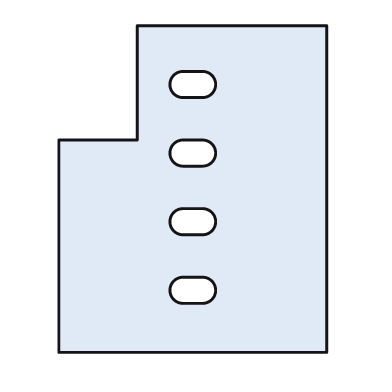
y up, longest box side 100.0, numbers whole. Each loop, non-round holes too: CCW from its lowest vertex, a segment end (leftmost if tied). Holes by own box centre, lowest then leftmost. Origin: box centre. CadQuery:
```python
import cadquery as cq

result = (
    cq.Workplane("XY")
    .moveTo(-41.0, -50.0)
    .lineTo(41.0, -50.0)
    .lineTo(41.0, 50.0)
    .lineTo(-17.0, 50.0)
    .lineTo(-17.0, 15.0)
    .lineTo(-41.0, 15.0)
    .close()
    .moveTo(-3.0, -35.0)
    .lineTo(3.0, -35.0)
    .threePointArc((7.0, -31.0), (3.0, -27.0))
    .lineTo(-3.0, -27.0)
    .threePointArc((-7.0, -31.0), (-3.0, -35.0))
    .close()
    .moveTo(-3.0, -14.0)
    .lineTo(3.0, -14.0)
    .threePointArc((7.0, -10.0), (3.0, -6.0))
    .lineTo(-3.0, -6.0)
    .threePointArc((-7.0, -10.0), (-3.0, -14.0))
    .close()
    .moveTo(-3.0, 7.0)
    .lineTo(3.0, 7.0)
    .threePointArc((7.0, 11.0), (3.0, 15.0))
    .lineTo(-3.0, 15.0)
    .threePointArc((-7.0, 11.0), (-3.0, 7.0))
    .close()
    .moveTo(-3.0, 28.0)
    .lineTo(3.0, 28.0)
    .threePointArc((7.0, 32.0), (3.0, 36.0))
    .lineTo(-3.0, 36.0)
    .threePointArc((-7.0, 32.0), (-3.0, 28.0))
    .close()
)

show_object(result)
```